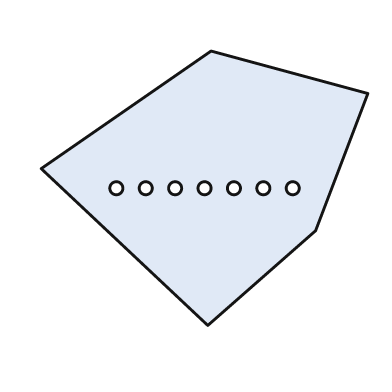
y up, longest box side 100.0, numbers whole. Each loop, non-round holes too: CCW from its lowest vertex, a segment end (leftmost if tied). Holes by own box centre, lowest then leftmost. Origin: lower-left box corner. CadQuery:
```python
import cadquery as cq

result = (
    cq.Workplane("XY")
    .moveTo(51.0, 0.0)
    .lineTo(84.0, 29.0)
    .lineTo(100.0, 71.0)
    .lineTo(52.0, 84.0)
    .lineTo(0.0, 48.0)
    .close()
    .moveTo(23.0, 42.0)
    .circle(2.0)
    .moveTo(32.0, 42.0)
    .circle(2.0)
    .moveTo(41.0, 42.0)
    .circle(2.0)
    .moveTo(50.0, 42.0)
    .circle(2.0)
    .moveTo(59.0, 42.0)
    .circle(2.0)
    .moveTo(68.0, 42.0)
    .circle(2.0)
    .moveTo(77.0, 42.0)
    .circle(2.0)
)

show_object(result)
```